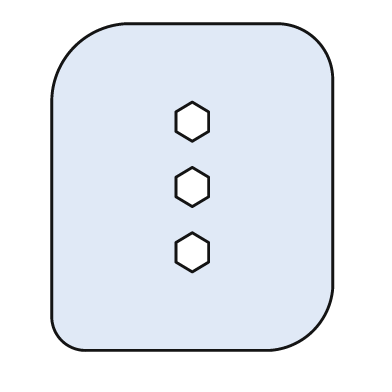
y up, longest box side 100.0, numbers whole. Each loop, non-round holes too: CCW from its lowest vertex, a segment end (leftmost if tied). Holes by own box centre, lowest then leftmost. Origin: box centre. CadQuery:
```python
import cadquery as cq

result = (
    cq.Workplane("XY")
    .moveTo(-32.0, -50.0)
    .lineTo(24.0, -50.0)
    .threePointArc((37.0, -44.0), (43.0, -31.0))
    .lineTo(43.0, 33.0)
    .threePointArc((38.0, 45.0), (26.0, 50.0))
    .lineTo(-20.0, 50.0)
    .threePointArc((-36.0, 43.0), (-43.0, 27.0))
    .lineTo(-43.0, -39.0)
    .threePointArc((-40.0, -47.0), (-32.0, -50.0))
    .close()
    .moveTo(0.0, -26.0)
    .lineTo(5.0, -23.0)
    .lineTo(5.0, -17.0)
    .lineTo(0.0, -14.0)
    .lineTo(-5.0, -17.0)
    .lineTo(-5.0, -23.0)
    .close()
    .moveTo(0.0, -6.0)
    .lineTo(5.0, -3.0)
    .lineTo(5.0, 3.0)
    .lineTo(0.0, 6.0)
    .lineTo(-5.0, 3.0)
    .lineTo(-5.0, -3.0)
    .close()
    .moveTo(0.0, 14.0)
    .lineTo(5.0, 17.0)
    .lineTo(5.0, 23.0)
    .lineTo(0.0, 26.0)
    .lineTo(-5.0, 23.0)
    .lineTo(-5.0, 17.0)
    .close()
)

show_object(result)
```